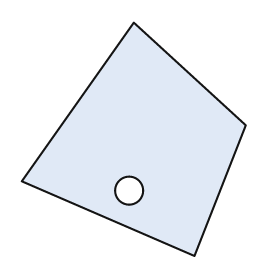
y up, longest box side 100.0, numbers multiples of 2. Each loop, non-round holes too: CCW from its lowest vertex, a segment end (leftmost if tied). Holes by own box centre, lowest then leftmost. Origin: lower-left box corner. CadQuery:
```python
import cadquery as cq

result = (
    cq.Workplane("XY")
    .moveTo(74.0, 0.0)
    .lineTo(96.0, 56.0)
    .lineTo(48.0, 100.0)
    .lineTo(0.0, 32.0)
    .close()
    .moveTo(46.0, 28.0)
    .circle(6.0)
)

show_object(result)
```